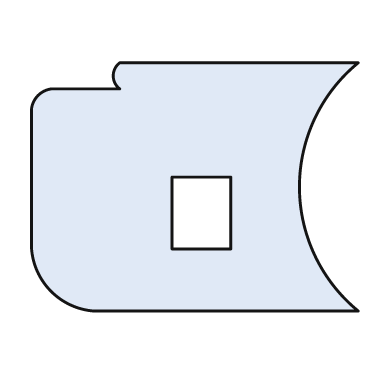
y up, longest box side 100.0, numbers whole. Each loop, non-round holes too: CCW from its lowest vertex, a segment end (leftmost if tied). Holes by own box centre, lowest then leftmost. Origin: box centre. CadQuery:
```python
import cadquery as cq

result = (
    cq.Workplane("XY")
    .moveTo(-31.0, -38.0)
    .lineTo(50.0, -38.0)
    .threePointArc((32.0, 0.0), (50.0, 38.0))
    .lineTo(-23.0, 38.0)
    .threePointArc((-25.0, 34.0), (-23.0, 30.0))
    .lineTo(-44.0, 30.0)
    .threePointArc((-48.0, 28.0), (-50.0, 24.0))
    .lineTo(-50.0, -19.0)
    .threePointArc((-44.0, -32.0), (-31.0, -38.0))
    .close()
    .moveTo(-7.0, -19.0)
    .lineTo(11.0, -19.0)
    .lineTo(11.0, 3.0)
    .lineTo(-7.0, 3.0)
    .close()
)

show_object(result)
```